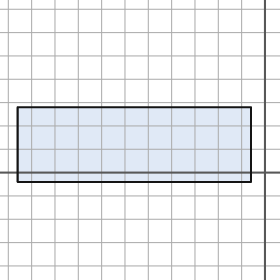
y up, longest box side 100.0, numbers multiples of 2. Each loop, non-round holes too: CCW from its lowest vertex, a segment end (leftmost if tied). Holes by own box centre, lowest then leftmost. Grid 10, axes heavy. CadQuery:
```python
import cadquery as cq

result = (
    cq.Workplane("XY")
    .moveTo(-106.0, -4.0)
    .lineTo(-6.0, -4.0)
    .lineTo(-6.0, 28.0)
    .lineTo(-106.0, 28.0)
    .close()
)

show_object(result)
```